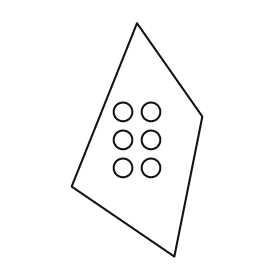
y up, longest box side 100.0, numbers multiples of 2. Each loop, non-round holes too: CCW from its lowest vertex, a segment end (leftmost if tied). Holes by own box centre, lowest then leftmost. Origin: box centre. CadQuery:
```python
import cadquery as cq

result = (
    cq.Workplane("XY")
    .moveTo(16.0, -50.0)
    .lineTo(28.0, 10.0)
    .lineTo(0.0, 50.0)
    .lineTo(-28.0, -20.0)
    .close()
    .moveTo(-6.0, -12.0)
    .circle(4.0)
    .moveTo(6.0, -12.0)
    .circle(4.0)
    .moveTo(-6.0, 0.0)
    .circle(4.0)
    .moveTo(6.0, 0.0)
    .circle(4.0)
    .moveTo(-6.0, 12.0)
    .circle(4.0)
    .moveTo(6.0, 12.0)
    .circle(4.0)
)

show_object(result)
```